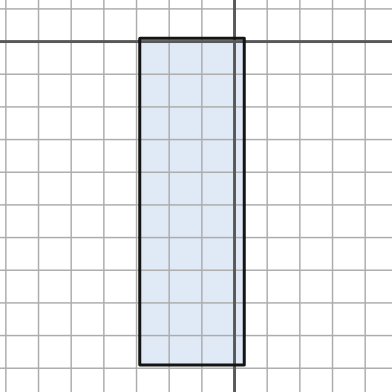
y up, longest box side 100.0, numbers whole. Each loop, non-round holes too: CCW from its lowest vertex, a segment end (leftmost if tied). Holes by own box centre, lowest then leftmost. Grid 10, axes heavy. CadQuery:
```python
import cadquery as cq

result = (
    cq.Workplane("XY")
    .moveTo(-29.0, -99.0)
    .lineTo(3.0, -99.0)
    .lineTo(3.0, 1.0)
    .lineTo(-29.0, 1.0)
    .close()
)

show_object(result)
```